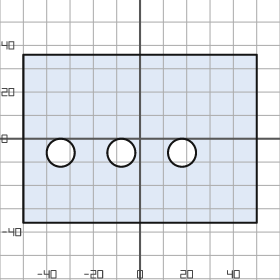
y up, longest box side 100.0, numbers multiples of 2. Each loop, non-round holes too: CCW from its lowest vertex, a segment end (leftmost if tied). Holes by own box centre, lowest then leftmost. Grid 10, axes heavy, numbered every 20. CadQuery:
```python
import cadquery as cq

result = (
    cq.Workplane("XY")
    .moveTo(-50.0, -36.0)
    .lineTo(50.0, -36.0)
    .lineTo(50.0, 36.0)
    .lineTo(-50.0, 36.0)
    .close()
    .moveTo(-34.0, -6.0)
    .circle(6.0)
    .moveTo(-8.0, -6.0)
    .circle(6.0)
    .moveTo(18.0, -6.0)
    .circle(6.0)
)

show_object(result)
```